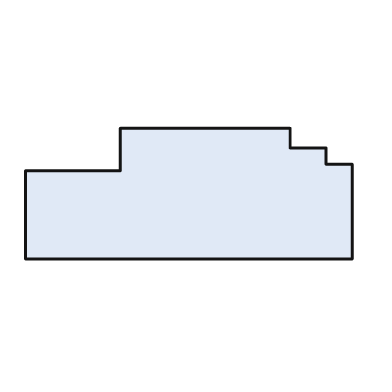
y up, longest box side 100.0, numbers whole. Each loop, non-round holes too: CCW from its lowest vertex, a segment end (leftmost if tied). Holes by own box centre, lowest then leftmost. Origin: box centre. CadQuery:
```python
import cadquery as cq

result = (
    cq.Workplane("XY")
    .moveTo(-50.0, -20.0)
    .lineTo(50.0, -20.0)
    .lineTo(50.0, 9.0)
    .lineTo(42.0, 9.0)
    .lineTo(42.0, 14.0)
    .lineTo(31.0, 14.0)
    .lineTo(31.0, 20.0)
    .lineTo(-21.0, 20.0)
    .lineTo(-21.0, 7.0)
    .lineTo(-50.0, 7.0)
    .close()
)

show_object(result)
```